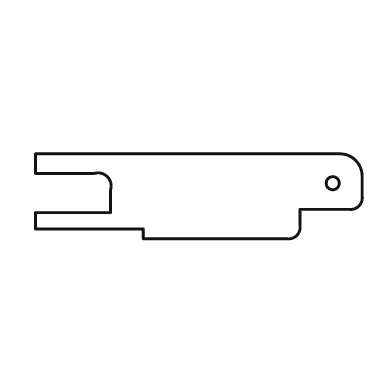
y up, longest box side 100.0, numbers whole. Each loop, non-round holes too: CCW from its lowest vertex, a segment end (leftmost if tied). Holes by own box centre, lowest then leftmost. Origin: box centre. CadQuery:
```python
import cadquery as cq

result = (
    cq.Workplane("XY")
    .moveTo(-17.0, -13.0)
    .lineTo(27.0, -13.0)
    .threePointArc((30.0, -12.0), (31.0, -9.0))
    .lineTo(31.0, -4.0)
    .lineTo(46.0, -4.0)
    .threePointArc((49.0, -3.0), (50.0, 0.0))
    .lineTo(50.0, 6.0)
    .threePointArc((48.0, 11.0), (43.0, 13.0))
    .lineTo(-50.0, 13.0)
    .lineTo(-50.0, 7.0)
    .lineTo(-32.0, 7.0)
    .threePointArc((-28.0, 6.0), (-27.0, 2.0))
    .lineTo(-27.0, -5.0)
    .lineTo(-50.0, -5.0)
    .lineTo(-50.0, -10.0)
    .lineTo(-17.0, -10.0)
    .close()
    .moveTo(41.0, 4.0)
    .circle(2.0)
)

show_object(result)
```